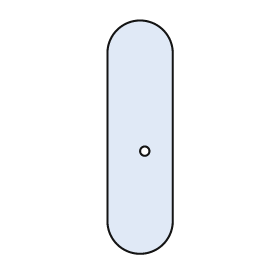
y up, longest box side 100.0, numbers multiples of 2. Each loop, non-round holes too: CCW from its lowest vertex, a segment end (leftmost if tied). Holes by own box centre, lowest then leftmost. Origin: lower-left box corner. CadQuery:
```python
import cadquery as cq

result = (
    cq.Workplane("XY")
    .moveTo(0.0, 14.0)
    .threePointArc((14.0, 0.0), (28.0, 14.0))
    .lineTo(28.0, 86.0)
    .threePointArc((14.0, 100.0), (0.0, 86.0))
    .close()
    .moveTo(16.0, 44.0)
    .circle(2.0)
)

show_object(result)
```